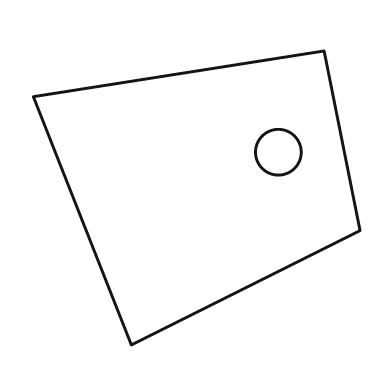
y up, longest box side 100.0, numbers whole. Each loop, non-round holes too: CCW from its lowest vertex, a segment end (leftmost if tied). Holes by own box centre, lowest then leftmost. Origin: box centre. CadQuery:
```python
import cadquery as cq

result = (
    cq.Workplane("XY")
    .moveTo(-20.0, -45.0)
    .lineTo(50.0, -10.0)
    .lineTo(39.0, 45.0)
    .lineTo(-50.0, 31.0)
    .close()
    .moveTo(25.0, 14.0)
    .circle(7.0)
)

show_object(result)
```